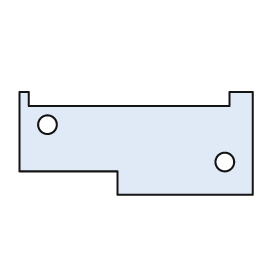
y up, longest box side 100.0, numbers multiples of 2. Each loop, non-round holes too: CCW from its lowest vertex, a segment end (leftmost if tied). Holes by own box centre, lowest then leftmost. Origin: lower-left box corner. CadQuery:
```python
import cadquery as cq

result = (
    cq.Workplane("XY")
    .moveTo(42.0, 0.0)
    .lineTo(100.0, 0.0)
    .lineTo(100.0, 44.0)
    .lineTo(90.0, 44.0)
    .lineTo(90.0, 38.0)
    .lineTo(4.0, 38.0)
    .lineTo(4.0, 44.0)
    .lineTo(0.0, 44.0)
    .lineTo(0.0, 10.0)
    .lineTo(42.0, 10.0)
    .close()
    .moveTo(88.0, 14.0)
    .circle(4.0)
    .moveTo(12.0, 30.0)
    .circle(4.0)
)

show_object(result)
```